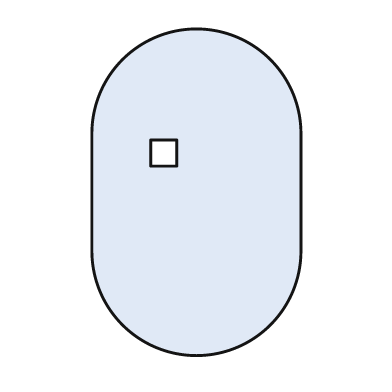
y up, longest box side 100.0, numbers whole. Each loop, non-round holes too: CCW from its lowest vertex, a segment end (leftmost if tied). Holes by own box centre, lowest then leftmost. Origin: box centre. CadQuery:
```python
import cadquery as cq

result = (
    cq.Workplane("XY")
    .moveTo(-32.0, -18.0)
    .threePointArc((0.0, -50.0), (32.0, -18.0))
    .lineTo(32.0, 18.0)
    .threePointArc((0.0, 50.0), (-32.0, 18.0))
    .close()
    .moveTo(-14.0, 8.0)
    .lineTo(-6.0, 8.0)
    .lineTo(-6.0, 16.0)
    .lineTo(-14.0, 16.0)
    .close()
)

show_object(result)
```